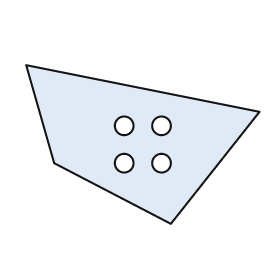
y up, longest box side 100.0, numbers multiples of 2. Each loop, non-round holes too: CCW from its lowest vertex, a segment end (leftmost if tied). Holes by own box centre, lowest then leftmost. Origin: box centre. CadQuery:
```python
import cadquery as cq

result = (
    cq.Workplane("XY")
    .moveTo(12.0, -34.0)
    .lineTo(50.0, 14.0)
    .lineTo(-50.0, 34.0)
    .lineTo(-38.0, -8.0)
    .close()
    .moveTo(-8.0, -8.0)
    .circle(4.0)
    .moveTo(8.0, -8.0)
    .circle(4.0)
    .moveTo(-8.0, 8.0)
    .circle(4.0)
    .moveTo(8.0, 8.0)
    .circle(4.0)
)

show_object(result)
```